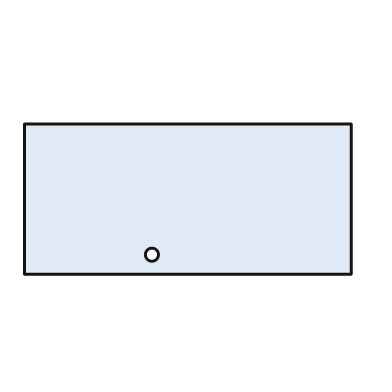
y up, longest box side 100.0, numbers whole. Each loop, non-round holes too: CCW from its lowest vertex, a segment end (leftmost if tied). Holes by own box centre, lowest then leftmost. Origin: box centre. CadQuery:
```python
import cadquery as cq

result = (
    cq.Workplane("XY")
    .moveTo(-50.0, -23.0)
    .lineTo(50.0, -23.0)
    .lineTo(50.0, 23.0)
    .lineTo(-50.0, 23.0)
    .close()
    .moveTo(-11.0, -17.0)
    .circle(2.0)
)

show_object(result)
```